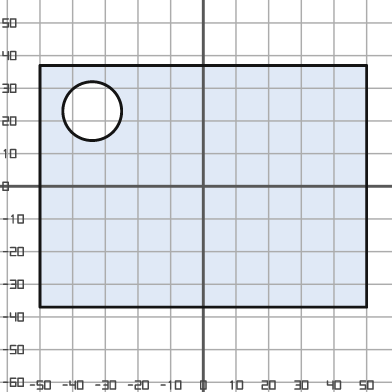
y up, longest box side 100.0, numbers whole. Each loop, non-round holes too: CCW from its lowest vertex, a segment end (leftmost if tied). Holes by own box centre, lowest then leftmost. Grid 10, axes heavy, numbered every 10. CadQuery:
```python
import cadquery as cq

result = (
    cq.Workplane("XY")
    .moveTo(-50.0, -37.0)
    .lineTo(50.0, -37.0)
    .lineTo(50.0, 37.0)
    .lineTo(-50.0, 37.0)
    .close()
    .moveTo(-34.0, 23.0)
    .circle(9.0)
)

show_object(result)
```